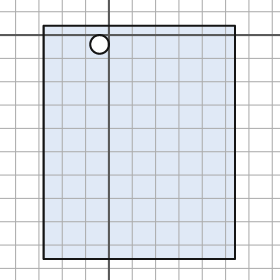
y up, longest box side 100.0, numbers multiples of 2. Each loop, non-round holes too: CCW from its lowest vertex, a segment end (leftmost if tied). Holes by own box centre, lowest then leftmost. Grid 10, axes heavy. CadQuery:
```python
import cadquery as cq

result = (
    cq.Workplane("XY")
    .moveTo(-28.0, -96.0)
    .lineTo(54.0, -96.0)
    .lineTo(54.0, 4.0)
    .lineTo(-28.0, 4.0)
    .close()
    .moveTo(-4.0, -4.0)
    .circle(4.0)
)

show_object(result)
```